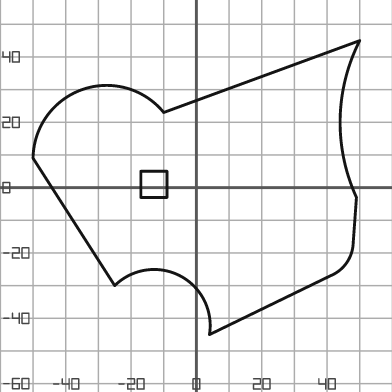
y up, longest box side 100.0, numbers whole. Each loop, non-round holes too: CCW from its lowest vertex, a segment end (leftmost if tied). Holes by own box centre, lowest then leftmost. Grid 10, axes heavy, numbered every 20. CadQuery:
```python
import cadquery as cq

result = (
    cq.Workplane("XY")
    .moveTo(4.0, -45.0)
    .lineTo(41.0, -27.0)
    .threePointArc((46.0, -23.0), (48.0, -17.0))
    .lineTo(49.0, -3.0)
    .threePointArc((44.0, 21.0), (50.0, 45.0))
    .lineTo(-10.0, 23.0)
    .threePointArc((-35.0, 30.0), (-50.0, 9.0))
    .lineTo(-25.0, -30.0)
    .threePointArc((-5.0, -27.0), (4.0, -45.0))
    .close()
    .moveTo(-17.0, -3.0)
    .lineTo(-9.0, -3.0)
    .lineTo(-9.0, 5.0)
    .lineTo(-17.0, 5.0)
    .close()
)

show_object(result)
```